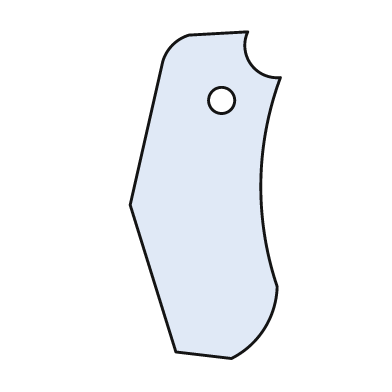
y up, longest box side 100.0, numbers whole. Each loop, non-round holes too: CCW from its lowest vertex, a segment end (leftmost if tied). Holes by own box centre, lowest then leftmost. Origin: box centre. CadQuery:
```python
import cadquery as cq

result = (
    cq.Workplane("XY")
    .moveTo(8.0, -50.0)
    .threePointArc((18.0, -41.0), (22.0, -28.0))
    .threePointArc((17.0, 4.0), (23.0, 36.0))
    .threePointArc((14.0, 40.0), (13.0, 50.0))
    .lineTo(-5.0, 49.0)
    .threePointArc((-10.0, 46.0), (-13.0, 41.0))
    .lineTo(-23.0, -3.0)
    .lineTo(-9.0, -48.0)
    .close()
    .moveTo(5.0, 29.0)
    .circle(4.0)
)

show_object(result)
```